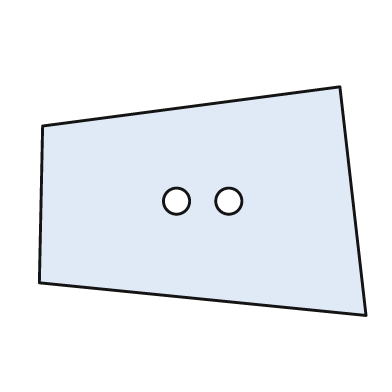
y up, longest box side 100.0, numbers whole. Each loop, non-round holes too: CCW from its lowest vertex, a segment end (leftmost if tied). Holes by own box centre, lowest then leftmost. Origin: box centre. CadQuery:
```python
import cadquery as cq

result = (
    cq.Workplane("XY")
    .moveTo(50.0, -35.0)
    .lineTo(42.0, 35.0)
    .lineTo(-49.0, 23.0)
    .lineTo(-50.0, -25.0)
    .close()
    .moveTo(-8.0, 0.0)
    .circle(4.0)
    .moveTo(8.0, 0.0)
    .circle(4.0)
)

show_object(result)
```